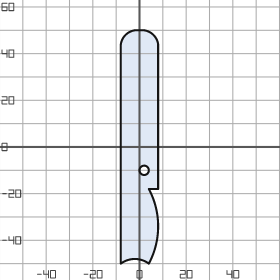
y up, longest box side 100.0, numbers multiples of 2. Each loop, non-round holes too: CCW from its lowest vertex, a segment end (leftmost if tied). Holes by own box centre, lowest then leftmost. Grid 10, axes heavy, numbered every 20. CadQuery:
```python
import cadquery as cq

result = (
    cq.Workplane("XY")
    .moveTo(-8.0, -50.0)
    .threePointArc((-2.0, -48.0), (4.0, -50.0))
    .threePointArc((8.0, -34.0), (4.0, -18.0))
    .lineTo(8.0, -18.0)
    .lineTo(8.0, 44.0)
    .threePointArc((6.0, 48.0), (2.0, 50.0))
    .lineTo(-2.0, 50.0)
    .threePointArc((-6.0, 48.0), (-8.0, 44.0))
    .close()
    .moveTo(2.0, -10.0)
    .circle(2.0)
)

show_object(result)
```